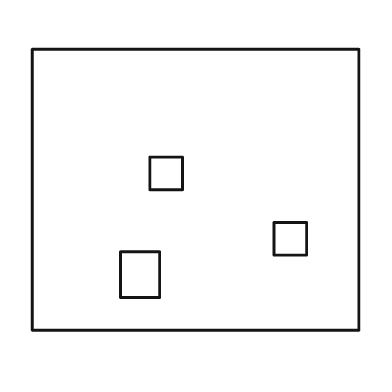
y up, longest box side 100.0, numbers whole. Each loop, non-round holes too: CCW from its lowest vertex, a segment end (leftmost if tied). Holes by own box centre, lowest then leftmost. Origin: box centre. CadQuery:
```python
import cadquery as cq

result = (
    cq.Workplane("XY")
    .moveTo(-50.0, -43.0)
    .lineTo(50.0, -43.0)
    .lineTo(50.0, 43.0)
    .lineTo(-50.0, 43.0)
    .close()
    .moveTo(-23.0, -33.0)
    .lineTo(-11.0, -33.0)
    .lineTo(-11.0, -19.0)
    .lineTo(-23.0, -19.0)
    .close()
    .moveTo(24.0, -20.0)
    .lineTo(34.0, -20.0)
    .lineTo(34.0, -10.0)
    .lineTo(24.0, -10.0)
    .close()
    .moveTo(-14.0, 0.0)
    .lineTo(-4.0, 0.0)
    .lineTo(-4.0, 10.0)
    .lineTo(-14.0, 10.0)
    .close()
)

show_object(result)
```